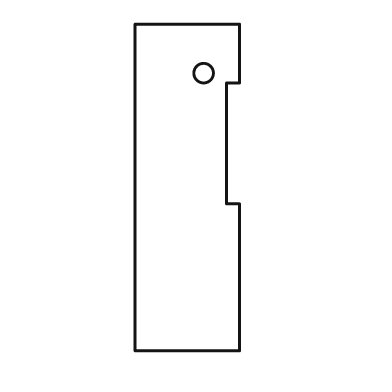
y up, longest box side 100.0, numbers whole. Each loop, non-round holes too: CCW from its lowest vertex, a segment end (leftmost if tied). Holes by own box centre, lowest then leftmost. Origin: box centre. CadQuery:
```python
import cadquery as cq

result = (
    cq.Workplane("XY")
    .moveTo(-16.0, -50.0)
    .lineTo(16.0, -50.0)
    .lineTo(16.0, -5.0)
    .lineTo(12.0, -5.0)
    .lineTo(12.0, 32.0)
    .lineTo(16.0, 32.0)
    .lineTo(16.0, 50.0)
    .lineTo(-16.0, 50.0)
    .close()
    .moveTo(5.0, 35.0)
    .circle(3.0)
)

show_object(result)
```